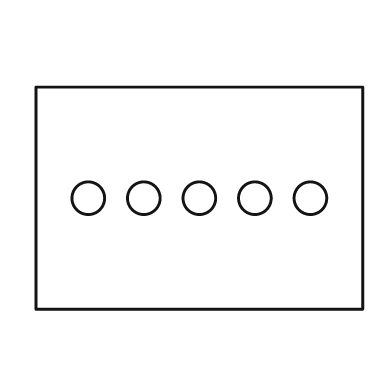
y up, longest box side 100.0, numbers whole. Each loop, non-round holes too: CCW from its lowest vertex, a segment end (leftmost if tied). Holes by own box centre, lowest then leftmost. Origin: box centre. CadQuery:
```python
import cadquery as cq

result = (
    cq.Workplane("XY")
    .moveTo(-50.0, -34.0)
    .lineTo(50.0, -34.0)
    .lineTo(50.0, 34.0)
    .lineTo(-50.0, 34.0)
    .close()
    .moveTo(-34.0, 0.0)
    .circle(5.0)
    .moveTo(-17.0, 0.0)
    .circle(5.0)
    .moveTo(0.0, 0.0)
    .circle(5.0)
    .moveTo(17.0, 0.0)
    .circle(5.0)
    .moveTo(34.0, 0.0)
    .circle(5.0)
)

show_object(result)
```